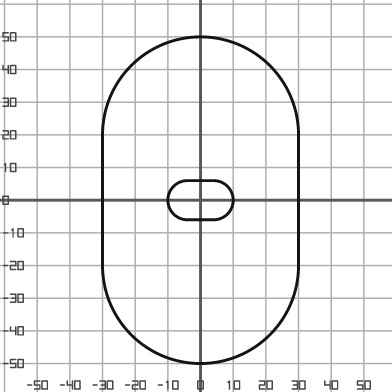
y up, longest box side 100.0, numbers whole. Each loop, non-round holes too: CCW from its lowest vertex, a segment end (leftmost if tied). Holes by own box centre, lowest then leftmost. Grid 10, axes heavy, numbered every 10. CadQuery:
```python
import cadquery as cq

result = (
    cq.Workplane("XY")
    .moveTo(-30.0, -20.0)
    .threePointArc((0.0, -50.0), (30.0, -20.0))
    .lineTo(30.0, 20.0)
    .threePointArc((0.0, 50.0), (-30.0, 20.0))
    .close()
    .moveTo(-4.0, -6.0)
    .lineTo(4.0, -6.0)
    .threePointArc((10.0, 0.0), (4.0, 6.0))
    .lineTo(-4.0, 6.0)
    .threePointArc((-10.0, 0.0), (-4.0, -6.0))
    .close()
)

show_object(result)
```